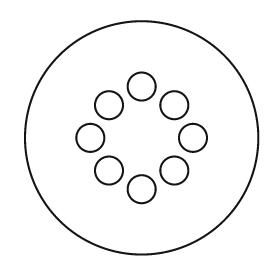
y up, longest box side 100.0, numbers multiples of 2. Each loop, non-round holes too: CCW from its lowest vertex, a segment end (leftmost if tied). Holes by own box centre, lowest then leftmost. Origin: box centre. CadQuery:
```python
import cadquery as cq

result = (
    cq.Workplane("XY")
    .moveTo(0.0, 0.0)
    .circle(50.0)
    .moveTo(0.0, -22.0)
    .circle(6.0)
    .moveTo(-14.0, -14.0)
    .circle(6.0)
    .moveTo(14.0, -14.0)
    .circle(6.0)
    .moveTo(-22.0, 0.0)
    .circle(6.0)
    .moveTo(22.0, 0.0)
    .circle(6.0)
    .moveTo(-14.0, 14.0)
    .circle(6.0)
    .moveTo(14.0, 14.0)
    .circle(6.0)
    .moveTo(0.0, 22.0)
    .circle(6.0)
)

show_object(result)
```